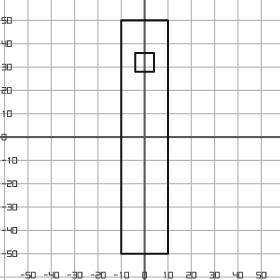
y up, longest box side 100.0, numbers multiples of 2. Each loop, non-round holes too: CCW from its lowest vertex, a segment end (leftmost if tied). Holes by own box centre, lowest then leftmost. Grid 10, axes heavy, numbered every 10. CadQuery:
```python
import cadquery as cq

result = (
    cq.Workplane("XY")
    .moveTo(-10.0, -50.0)
    .lineTo(10.0, -50.0)
    .lineTo(10.0, 50.0)
    .lineTo(-10.0, 50.0)
    .close()
    .moveTo(-4.0, 28.0)
    .lineTo(4.0, 28.0)
    .lineTo(4.0, 36.0)
    .lineTo(-4.0, 36.0)
    .close()
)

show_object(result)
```